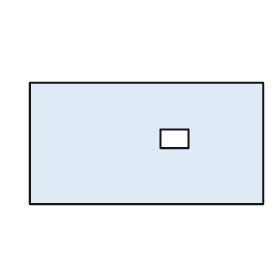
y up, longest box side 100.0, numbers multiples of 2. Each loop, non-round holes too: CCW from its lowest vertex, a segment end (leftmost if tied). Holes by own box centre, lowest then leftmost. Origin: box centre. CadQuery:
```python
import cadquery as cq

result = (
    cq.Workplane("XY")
    .moveTo(-50.0, -26.0)
    .lineTo(50.0, -26.0)
    .lineTo(50.0, 26.0)
    .lineTo(-50.0, 26.0)
    .close()
    .moveTo(6.0, -2.0)
    .lineTo(18.0, -2.0)
    .lineTo(18.0, 6.0)
    .lineTo(6.0, 6.0)
    .close()
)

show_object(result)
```